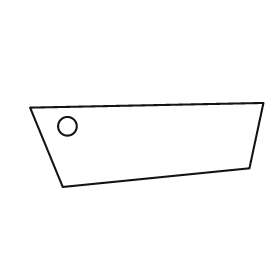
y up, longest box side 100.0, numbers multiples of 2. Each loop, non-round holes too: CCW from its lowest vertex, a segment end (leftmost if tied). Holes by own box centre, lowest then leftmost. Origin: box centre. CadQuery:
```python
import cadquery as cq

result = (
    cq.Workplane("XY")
    .moveTo(-36.0, -18.0)
    .lineTo(44.0, -10.0)
    .lineTo(50.0, 18.0)
    .lineTo(-50.0, 16.0)
    .close()
    .moveTo(-34.0, 8.0)
    .circle(4.0)
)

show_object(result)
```